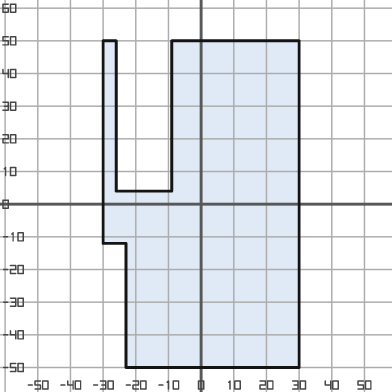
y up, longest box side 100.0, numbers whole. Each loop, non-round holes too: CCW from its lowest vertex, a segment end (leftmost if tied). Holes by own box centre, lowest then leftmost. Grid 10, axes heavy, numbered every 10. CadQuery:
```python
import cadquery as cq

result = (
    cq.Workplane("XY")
    .moveTo(-23.0, -50.0)
    .lineTo(30.0, -50.0)
    .lineTo(30.0, 50.0)
    .lineTo(-9.0, 50.0)
    .lineTo(-9.0, 4.0)
    .lineTo(-26.0, 4.0)
    .lineTo(-26.0, 50.0)
    .lineTo(-30.0, 50.0)
    .lineTo(-30.0, -12.0)
    .lineTo(-23.0, -12.0)
    .close()
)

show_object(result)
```